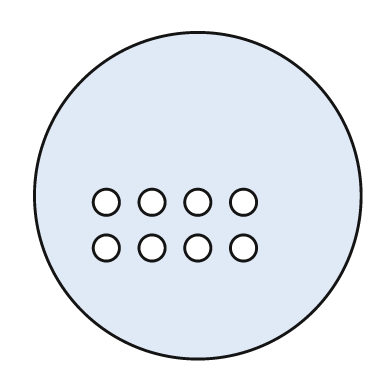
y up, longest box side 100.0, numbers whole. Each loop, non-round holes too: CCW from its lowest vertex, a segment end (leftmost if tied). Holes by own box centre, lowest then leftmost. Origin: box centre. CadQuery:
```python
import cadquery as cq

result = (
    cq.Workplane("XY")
    .moveTo(0.0, 0.0)
    .circle(50.0)
    .moveTo(-28.0, -16.0)
    .circle(4.0)
    .moveTo(-14.0, -16.0)
    .circle(4.0)
    .moveTo(0.0, -16.0)
    .circle(4.0)
    .moveTo(14.0, -16.0)
    .circle(4.0)
    .moveTo(-28.0, -2.0)
    .circle(4.0)
    .moveTo(-14.0, -2.0)
    .circle(4.0)
    .moveTo(0.0, -2.0)
    .circle(4.0)
    .moveTo(14.0, -2.0)
    .circle(4.0)
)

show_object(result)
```